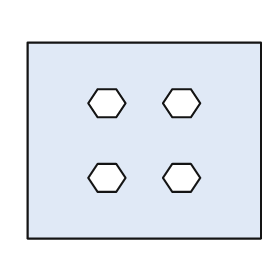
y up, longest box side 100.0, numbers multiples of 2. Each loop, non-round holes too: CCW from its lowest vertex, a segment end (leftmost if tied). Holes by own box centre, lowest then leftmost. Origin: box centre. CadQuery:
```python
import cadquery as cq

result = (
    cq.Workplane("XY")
    .moveTo(-50.0, -42.0)
    .lineTo(50.0, -42.0)
    .lineTo(50.0, 42.0)
    .lineTo(-50.0, 42.0)
    .close()
    .moveTo(-20.0, -22.0)
    .lineTo(-12.0, -22.0)
    .lineTo(-8.0, -16.0)
    .lineTo(-12.0, -10.0)
    .lineTo(-20.0, -10.0)
    .lineTo(-24.0, -16.0)
    .close()
    .moveTo(12.0, -22.0)
    .lineTo(20.0, -22.0)
    .lineTo(24.0, -16.0)
    .lineTo(20.0, -10.0)
    .lineTo(12.0, -10.0)
    .lineTo(8.0, -16.0)
    .close()
    .moveTo(-20.0, 10.0)
    .lineTo(-12.0, 10.0)
    .lineTo(-8.0, 16.0)
    .lineTo(-12.0, 22.0)
    .lineTo(-20.0, 22.0)
    .lineTo(-24.0, 16.0)
    .close()
    .moveTo(12.0, 10.0)
    .lineTo(20.0, 10.0)
    .lineTo(24.0, 16.0)
    .lineTo(20.0, 22.0)
    .lineTo(12.0, 22.0)
    .lineTo(8.0, 16.0)
    .close()
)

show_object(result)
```